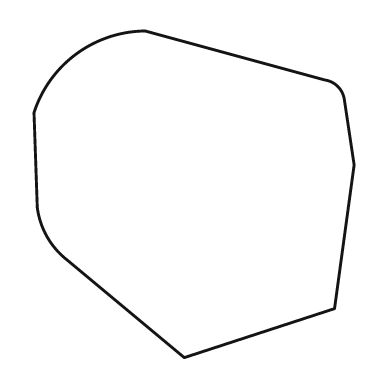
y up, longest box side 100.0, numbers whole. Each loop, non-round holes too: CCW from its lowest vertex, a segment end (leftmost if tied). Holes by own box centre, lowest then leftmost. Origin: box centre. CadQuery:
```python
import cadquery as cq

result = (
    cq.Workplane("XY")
    .moveTo(-3.0, -50.0)
    .lineTo(43.0, -35.0)
    .lineTo(49.0, 9.0)
    .lineTo(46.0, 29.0)
    .threePointArc((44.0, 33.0), (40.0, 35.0))
    .lineTo(-15.0, 50.0)
    .threePointArc((-36.0, 43.0), (-49.0, 25.0))
    .lineTo(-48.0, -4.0)
    .threePointArc((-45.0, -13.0), (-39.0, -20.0))
    .close()
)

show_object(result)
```